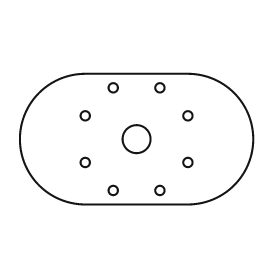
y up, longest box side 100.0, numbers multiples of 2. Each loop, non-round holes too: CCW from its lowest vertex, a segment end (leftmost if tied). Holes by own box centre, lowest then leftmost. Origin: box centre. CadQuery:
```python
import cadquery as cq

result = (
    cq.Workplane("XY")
    .moveTo(-22.0, -28.0)
    .lineTo(22.0, -28.0)
    .threePointArc((50.0, 0.0), (22.0, 28.0))
    .lineTo(-22.0, 28.0)
    .threePointArc((-50.0, 0.0), (-22.0, -28.0))
    .close()
    .moveTo(-10.0, -22.0)
    .circle(2.0)
    .moveTo(10.0, -22.0)
    .circle(2.0)
    .moveTo(-22.0, -10.0)
    .circle(2.0)
    .moveTo(22.0, -10.0)
    .circle(2.0)
    .moveTo(0.0, 0.0)
    .circle(6.0)
    .moveTo(-22.0, 10.0)
    .circle(2.0)
    .moveTo(22.0, 10.0)
    .circle(2.0)
    .moveTo(-10.0, 22.0)
    .circle(2.0)
    .moveTo(10.0, 22.0)
    .circle(2.0)
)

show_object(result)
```